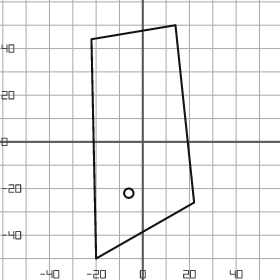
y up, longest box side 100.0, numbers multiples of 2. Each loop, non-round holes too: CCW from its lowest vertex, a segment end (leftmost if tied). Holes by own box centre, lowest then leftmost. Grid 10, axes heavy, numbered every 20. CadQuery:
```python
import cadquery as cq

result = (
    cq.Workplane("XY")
    .moveTo(-20.0, -50.0)
    .lineTo(22.0, -26.0)
    .lineTo(14.0, 50.0)
    .lineTo(-22.0, 44.0)
    .close()
    .moveTo(-6.0, -22.0)
    .circle(2.0)
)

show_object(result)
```